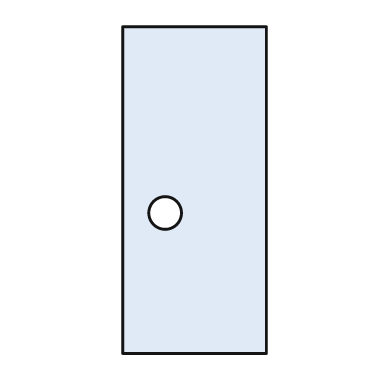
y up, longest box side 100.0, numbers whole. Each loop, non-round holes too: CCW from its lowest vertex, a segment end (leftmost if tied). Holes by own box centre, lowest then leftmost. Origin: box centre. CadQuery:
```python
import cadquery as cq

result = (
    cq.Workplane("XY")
    .moveTo(-22.0, -50.0)
    .lineTo(22.0, -50.0)
    .lineTo(22.0, 50.0)
    .lineTo(-22.0, 50.0)
    .close()
    .moveTo(-9.0, -7.0)
    .circle(5.0)
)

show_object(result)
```